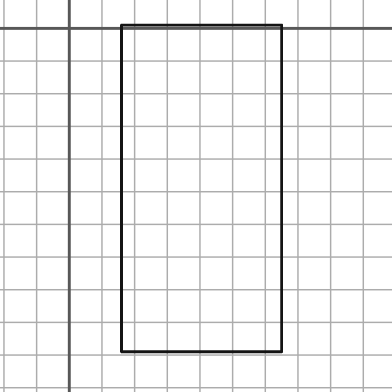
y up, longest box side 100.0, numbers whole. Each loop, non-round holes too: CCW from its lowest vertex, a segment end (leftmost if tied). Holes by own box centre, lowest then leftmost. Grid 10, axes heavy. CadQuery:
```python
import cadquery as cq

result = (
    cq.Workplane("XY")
    .moveTo(16.0, -99.0)
    .lineTo(65.0, -99.0)
    .lineTo(65.0, 1.0)
    .lineTo(16.0, 1.0)
    .close()
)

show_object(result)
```